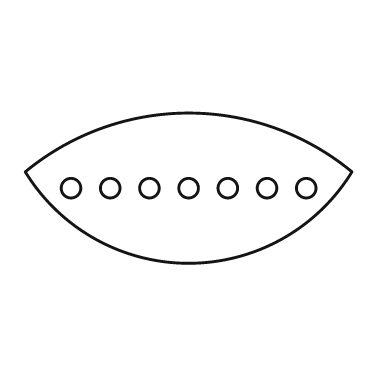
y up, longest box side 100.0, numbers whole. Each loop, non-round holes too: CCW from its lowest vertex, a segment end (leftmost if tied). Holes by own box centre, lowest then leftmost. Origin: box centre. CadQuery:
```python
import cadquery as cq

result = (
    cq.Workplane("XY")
    .moveTo(-50.0, 5.0)
    .threePointArc((0.0, -23.0), (50.0, 5.0))
    .threePointArc((0.0, 23.0), (-50.0, 5.0))
    .close()
    .moveTo(-36.0, 0.0)
    .circle(3.0)
    .moveTo(-24.0, 0.0)
    .circle(3.0)
    .moveTo(-12.0, 0.0)
    .circle(3.0)
    .moveTo(0.0, 0.0)
    .circle(3.0)
    .moveTo(12.0, 0.0)
    .circle(3.0)
    .moveTo(24.0, 0.0)
    .circle(3.0)
    .moveTo(36.0, 0.0)
    .circle(3.0)
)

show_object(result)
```